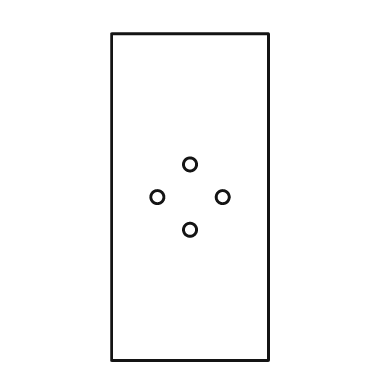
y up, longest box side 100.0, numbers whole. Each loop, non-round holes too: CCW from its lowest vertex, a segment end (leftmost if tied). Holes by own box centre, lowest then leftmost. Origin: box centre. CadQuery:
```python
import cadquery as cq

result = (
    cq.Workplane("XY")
    .moveTo(-24.0, -50.0)
    .lineTo(24.0, -50.0)
    .lineTo(24.0, 50.0)
    .lineTo(-24.0, 50.0)
    .close()
    .moveTo(0.0, -10.0)
    .circle(2.0)
    .moveTo(-10.0, 0.0)
    .circle(2.0)
    .moveTo(10.0, 0.0)
    .circle(2.0)
    .moveTo(0.0, 10.0)
    .circle(2.0)
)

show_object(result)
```